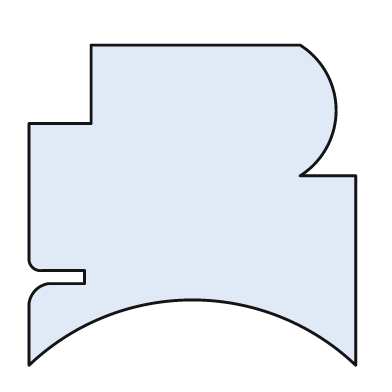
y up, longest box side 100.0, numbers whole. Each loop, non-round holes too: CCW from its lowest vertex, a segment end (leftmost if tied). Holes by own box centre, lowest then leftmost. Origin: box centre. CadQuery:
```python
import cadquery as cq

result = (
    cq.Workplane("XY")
    .moveTo(-50.0, -49.0)
    .threePointArc((0.0, -29.0), (50.0, -49.0))
    .lineTo(50.0, 9.0)
    .lineTo(33.0, 9.0)
    .threePointArc((44.0, 29.0), (33.0, 49.0))
    .lineTo(-31.0, 49.0)
    .lineTo(-31.0, 25.0)
    .lineTo(-50.0, 25.0)
    .lineTo(-50.0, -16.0)
    .threePointArc((-49.0, -19.0), (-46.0, -20.0))
    .lineTo(-33.0, -20.0)
    .lineTo(-33.0, -24.0)
    .lineTo(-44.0, -24.0)
    .threePointArc((-48.0, -26.0), (-50.0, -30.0))
    .close()
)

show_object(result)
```